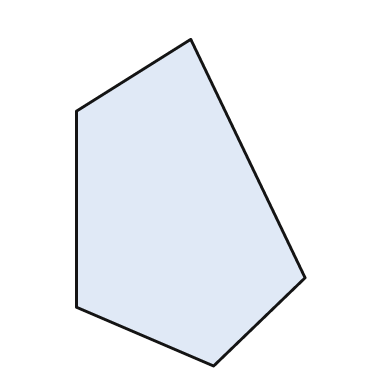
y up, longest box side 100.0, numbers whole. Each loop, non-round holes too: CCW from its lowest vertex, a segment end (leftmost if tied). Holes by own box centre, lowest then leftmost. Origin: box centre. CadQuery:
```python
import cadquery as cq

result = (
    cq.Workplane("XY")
    .moveTo(7.0, -50.0)
    .lineTo(35.0, -23.0)
    .lineTo(0.0, 50.0)
    .lineTo(-35.0, 28.0)
    .lineTo(-35.0, -32.0)
    .close()
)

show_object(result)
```